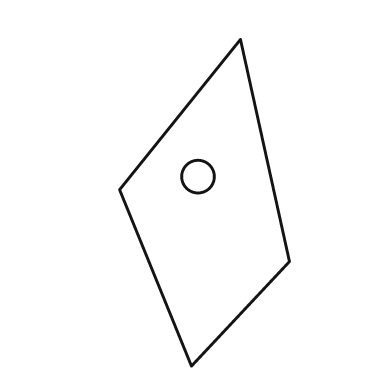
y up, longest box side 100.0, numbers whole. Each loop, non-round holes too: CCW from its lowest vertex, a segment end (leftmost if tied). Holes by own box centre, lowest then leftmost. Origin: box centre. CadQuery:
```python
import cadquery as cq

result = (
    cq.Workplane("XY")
    .moveTo(-4.0, -50.0)
    .lineTo(26.0, -18.0)
    .lineTo(11.0, 50.0)
    .lineTo(-26.0, 4.0)
    .close()
    .moveTo(-2.0, 8.0)
    .circle(5.0)
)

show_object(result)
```